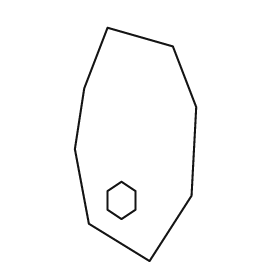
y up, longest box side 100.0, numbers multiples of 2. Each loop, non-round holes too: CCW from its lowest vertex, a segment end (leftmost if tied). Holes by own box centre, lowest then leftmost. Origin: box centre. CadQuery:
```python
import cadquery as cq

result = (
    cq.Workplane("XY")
    .moveTo(6.0, -50.0)
    .lineTo(24.0, -22.0)
    .lineTo(26.0, 16.0)
    .lineTo(16.0, 42.0)
    .lineTo(-12.0, 50.0)
    .lineTo(-22.0, 24.0)
    .lineTo(-26.0, -2.0)
    .lineTo(-20.0, -34.0)
    .close()
    .moveTo(-6.0, -32.0)
    .lineTo(0.0, -28.0)
    .lineTo(0.0, -20.0)
    .lineTo(-6.0, -16.0)
    .lineTo(-12.0, -20.0)
    .lineTo(-12.0, -28.0)
    .close()
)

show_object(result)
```